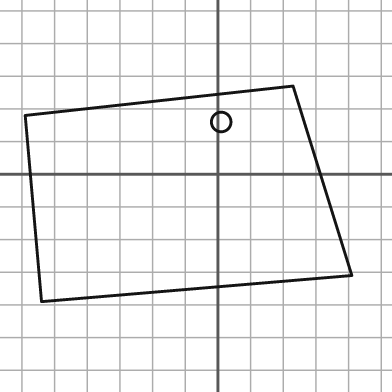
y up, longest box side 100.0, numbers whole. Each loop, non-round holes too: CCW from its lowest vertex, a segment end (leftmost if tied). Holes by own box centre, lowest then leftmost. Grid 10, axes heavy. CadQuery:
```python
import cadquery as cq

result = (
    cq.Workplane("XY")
    .moveTo(-54.0, -39.0)
    .lineTo(41.0, -31.0)
    .lineTo(23.0, 27.0)
    .lineTo(-59.0, 18.0)
    .close()
    .moveTo(1.0, 16.0)
    .circle(3.0)
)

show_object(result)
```